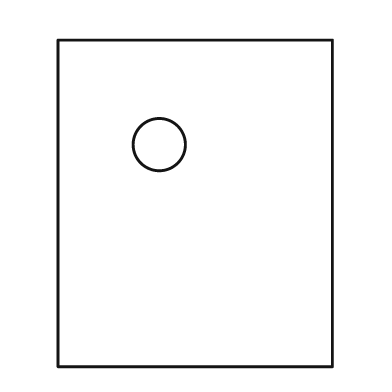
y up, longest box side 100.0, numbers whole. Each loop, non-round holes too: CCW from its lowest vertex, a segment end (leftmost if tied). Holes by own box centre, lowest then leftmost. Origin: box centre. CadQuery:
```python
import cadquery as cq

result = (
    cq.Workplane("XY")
    .moveTo(-42.0, -50.0)
    .lineTo(42.0, -50.0)
    .lineTo(42.0, 50.0)
    .lineTo(-42.0, 50.0)
    .close()
    .moveTo(-11.0, 18.0)
    .circle(8.0)
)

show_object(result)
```